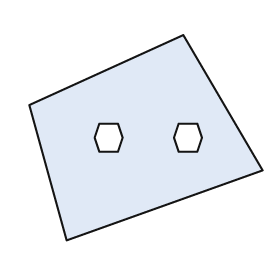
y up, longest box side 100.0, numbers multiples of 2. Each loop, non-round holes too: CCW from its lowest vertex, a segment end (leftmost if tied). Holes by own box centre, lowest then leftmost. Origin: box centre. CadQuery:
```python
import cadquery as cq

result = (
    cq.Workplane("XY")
    .moveTo(-34.0, -44.0)
    .lineTo(50.0, -14.0)
    .lineTo(16.0, 44.0)
    .lineTo(-50.0, 14.0)
    .close()
    .moveTo(-20.0, -6.0)
    .lineTo(-12.0, -6.0)
    .lineTo(-10.0, 0.0)
    .lineTo(-12.0, 6.0)
    .lineTo(-20.0, 6.0)
    .lineTo(-22.0, 0.0)
    .close()
    .moveTo(14.0, -6.0)
    .lineTo(22.0, -6.0)
    .lineTo(24.0, 0.0)
    .lineTo(22.0, 6.0)
    .lineTo(14.0, 6.0)
    .lineTo(12.0, 0.0)
    .close()
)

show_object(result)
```